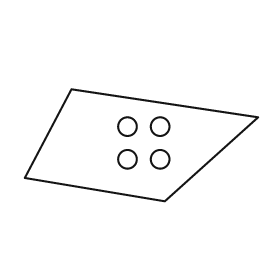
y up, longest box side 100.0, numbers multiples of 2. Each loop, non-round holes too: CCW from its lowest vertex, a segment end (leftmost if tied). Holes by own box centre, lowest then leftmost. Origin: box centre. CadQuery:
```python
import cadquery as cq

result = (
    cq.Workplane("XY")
    .moveTo(10.0, -24.0)
    .lineTo(50.0, 12.0)
    .lineTo(-30.0, 24.0)
    .lineTo(-50.0, -14.0)
    .close()
    .moveTo(-6.0, -6.0)
    .circle(4.0)
    .moveTo(8.0, -6.0)
    .circle(4.0)
    .moveTo(-6.0, 8.0)
    .circle(4.0)
    .moveTo(8.0, 8.0)
    .circle(4.0)
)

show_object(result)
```